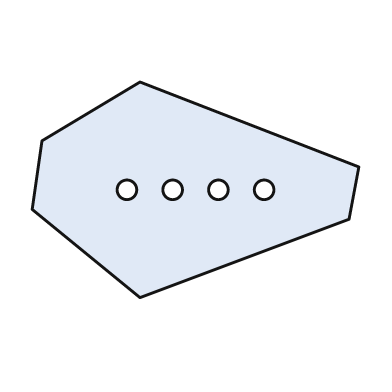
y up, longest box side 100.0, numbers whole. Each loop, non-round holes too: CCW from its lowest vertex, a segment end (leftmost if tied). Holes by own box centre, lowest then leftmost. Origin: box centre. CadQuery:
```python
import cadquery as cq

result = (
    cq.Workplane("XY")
    .moveTo(-17.0, -33.0)
    .lineTo(47.0, -9.0)
    .lineTo(50.0, 7.0)
    .lineTo(-17.0, 33.0)
    .lineTo(-47.0, 15.0)
    .lineTo(-50.0, -6.0)
    .close()
    .moveTo(-21.0, 0.0)
    .circle(3.0)
    .moveTo(-7.0, 0.0)
    .circle(3.0)
    .moveTo(7.0, 0.0)
    .circle(3.0)
    .moveTo(21.0, 0.0)
    .circle(3.0)
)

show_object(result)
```